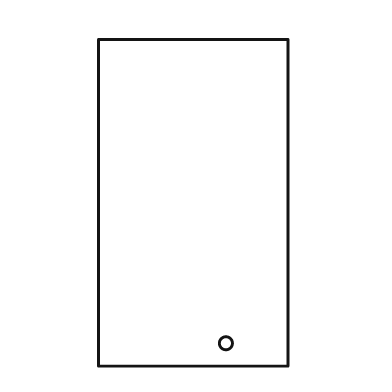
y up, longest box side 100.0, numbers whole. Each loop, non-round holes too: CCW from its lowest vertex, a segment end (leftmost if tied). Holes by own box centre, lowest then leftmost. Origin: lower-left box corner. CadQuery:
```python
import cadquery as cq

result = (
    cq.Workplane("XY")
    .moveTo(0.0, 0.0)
    .lineTo(58.0, 0.0)
    .lineTo(58.0, 100.0)
    .lineTo(0.0, 100.0)
    .close()
    .moveTo(39.0, 7.0)
    .circle(2.0)
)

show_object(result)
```